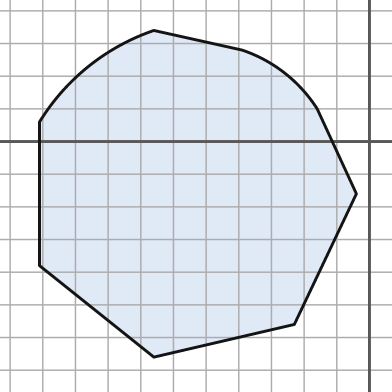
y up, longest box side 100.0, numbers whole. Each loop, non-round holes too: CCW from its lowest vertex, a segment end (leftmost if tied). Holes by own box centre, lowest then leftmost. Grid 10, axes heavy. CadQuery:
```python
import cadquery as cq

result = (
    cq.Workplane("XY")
    .moveTo(-66.0, -66.0)
    .lineTo(-23.0, -56.0)
    .lineTo(-4.0, -16.0)
    .lineTo(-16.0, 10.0)
    .threePointArc((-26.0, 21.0), (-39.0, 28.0))
    .lineTo(-66.0, 34.0)
    .threePointArc((-86.0, 23.0), (-101.0, 6.0))
    .lineTo(-101.0, -38.0)
    .close()
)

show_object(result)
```